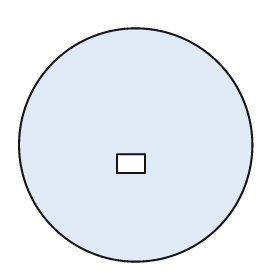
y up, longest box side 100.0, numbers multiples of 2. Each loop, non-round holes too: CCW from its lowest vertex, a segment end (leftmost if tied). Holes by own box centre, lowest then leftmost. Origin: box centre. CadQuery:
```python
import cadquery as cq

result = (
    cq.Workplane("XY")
    .moveTo(0.0, 0.0)
    .circle(50.0)
    .moveTo(-8.0, -12.0)
    .lineTo(4.0, -12.0)
    .lineTo(4.0, -4.0)
    .lineTo(-8.0, -4.0)
    .close()
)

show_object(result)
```